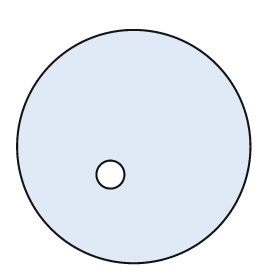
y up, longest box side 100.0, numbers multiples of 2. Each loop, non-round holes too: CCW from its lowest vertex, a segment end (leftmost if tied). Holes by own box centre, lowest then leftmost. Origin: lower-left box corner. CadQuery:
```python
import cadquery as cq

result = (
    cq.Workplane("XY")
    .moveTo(50.0, 50.0)
    .circle(50.0)
    .moveTo(40.0, 38.0)
    .circle(6.0)
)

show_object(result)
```